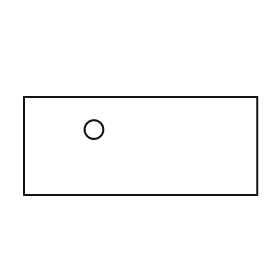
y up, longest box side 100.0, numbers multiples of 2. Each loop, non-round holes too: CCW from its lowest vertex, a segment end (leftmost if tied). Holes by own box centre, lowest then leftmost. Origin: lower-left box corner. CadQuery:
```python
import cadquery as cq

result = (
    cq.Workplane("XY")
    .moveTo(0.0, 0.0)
    .lineTo(100.0, 0.0)
    .lineTo(100.0, 42.0)
    .lineTo(0.0, 42.0)
    .close()
    .moveTo(30.0, 28.0)
    .circle(4.0)
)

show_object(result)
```